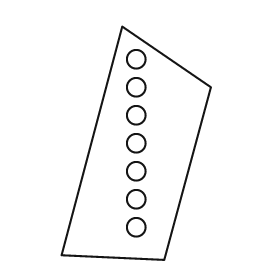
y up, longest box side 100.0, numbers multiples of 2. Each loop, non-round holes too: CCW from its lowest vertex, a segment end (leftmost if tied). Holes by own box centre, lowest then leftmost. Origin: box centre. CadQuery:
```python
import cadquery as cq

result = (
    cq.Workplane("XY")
    .moveTo(12.0, -50.0)
    .lineTo(32.0, 24.0)
    .lineTo(-6.0, 50.0)
    .lineTo(-32.0, -48.0)
    .close()
    .moveTo(0.0, -36.0)
    .circle(4.0)
    .moveTo(0.0, -24.0)
    .circle(4.0)
    .moveTo(0.0, -12.0)
    .circle(4.0)
    .moveTo(0.0, 0.0)
    .circle(4.0)
    .moveTo(0.0, 12.0)
    .circle(4.0)
    .moveTo(0.0, 24.0)
    .circle(4.0)
    .moveTo(0.0, 36.0)
    .circle(4.0)
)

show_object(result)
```